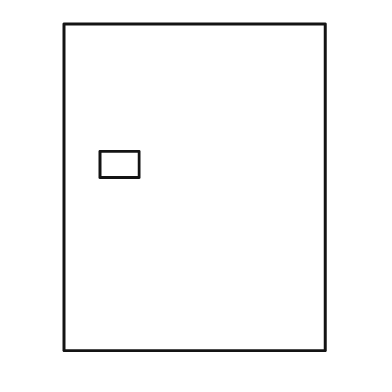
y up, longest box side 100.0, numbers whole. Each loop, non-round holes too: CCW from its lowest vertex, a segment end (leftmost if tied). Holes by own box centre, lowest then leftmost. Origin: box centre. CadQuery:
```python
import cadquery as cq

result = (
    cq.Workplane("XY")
    .moveTo(-40.0, -50.0)
    .lineTo(40.0, -50.0)
    .lineTo(40.0, 50.0)
    .lineTo(-40.0, 50.0)
    .close()
    .moveTo(-29.0, 3.0)
    .lineTo(-17.0, 3.0)
    .lineTo(-17.0, 11.0)
    .lineTo(-29.0, 11.0)
    .close()
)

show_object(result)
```